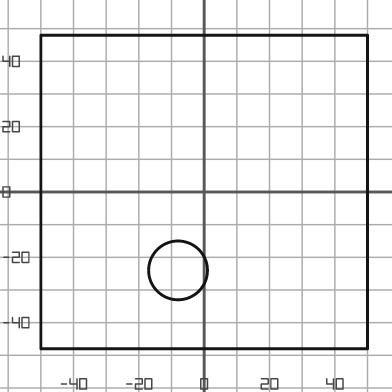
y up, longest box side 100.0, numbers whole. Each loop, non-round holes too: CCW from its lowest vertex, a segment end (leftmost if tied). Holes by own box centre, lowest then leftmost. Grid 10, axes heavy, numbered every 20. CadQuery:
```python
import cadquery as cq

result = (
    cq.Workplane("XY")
    .moveTo(-50.0, -48.0)
    .lineTo(50.0, -48.0)
    .lineTo(50.0, 48.0)
    .lineTo(-50.0, 48.0)
    .close()
    .moveTo(-8.0, -24.0)
    .circle(9.0)
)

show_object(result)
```